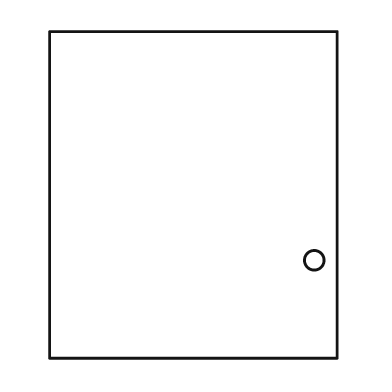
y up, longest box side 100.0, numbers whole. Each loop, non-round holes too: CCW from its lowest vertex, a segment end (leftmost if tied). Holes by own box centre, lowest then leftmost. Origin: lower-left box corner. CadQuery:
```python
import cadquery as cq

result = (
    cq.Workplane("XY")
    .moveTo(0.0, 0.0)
    .lineTo(88.0, 0.0)
    .lineTo(88.0, 100.0)
    .lineTo(0.0, 100.0)
    .close()
    .moveTo(81.0, 30.0)
    .circle(3.0)
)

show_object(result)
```